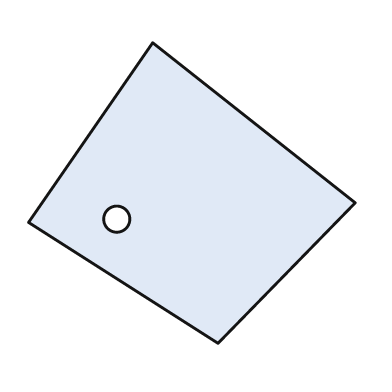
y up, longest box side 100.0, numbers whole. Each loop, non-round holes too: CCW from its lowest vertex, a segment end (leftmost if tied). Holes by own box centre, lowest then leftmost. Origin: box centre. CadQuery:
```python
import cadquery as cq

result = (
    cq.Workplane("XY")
    .moveTo(8.0, -46.0)
    .lineTo(50.0, -3.0)
    .lineTo(-12.0, 46.0)
    .lineTo(-50.0, -9.0)
    .close()
    .moveTo(-23.0, -8.0)
    .circle(4.0)
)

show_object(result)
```